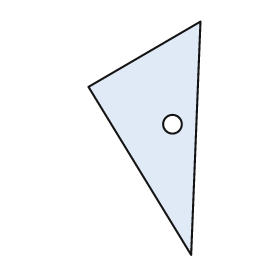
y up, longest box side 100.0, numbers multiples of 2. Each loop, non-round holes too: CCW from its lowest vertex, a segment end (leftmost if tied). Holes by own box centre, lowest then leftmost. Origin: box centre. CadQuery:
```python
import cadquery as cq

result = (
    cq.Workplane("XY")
    .moveTo(20.0, -50.0)
    .lineTo(24.0, 50.0)
    .lineTo(-24.0, 22.0)
    .close()
    .moveTo(12.0, 6.0)
    .circle(4.0)
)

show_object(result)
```